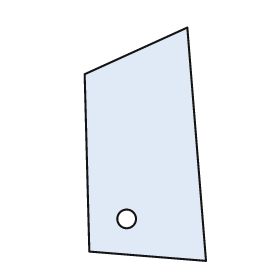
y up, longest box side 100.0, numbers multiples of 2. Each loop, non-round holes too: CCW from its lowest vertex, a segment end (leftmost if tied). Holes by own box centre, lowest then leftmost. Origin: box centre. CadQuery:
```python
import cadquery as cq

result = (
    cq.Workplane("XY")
    .moveTo(26.0, -50.0)
    .lineTo(18.0, 50.0)
    .lineTo(-26.0, 30.0)
    .lineTo(-24.0, -46.0)
    .close()
    .moveTo(-8.0, -32.0)
    .circle(4.0)
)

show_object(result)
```